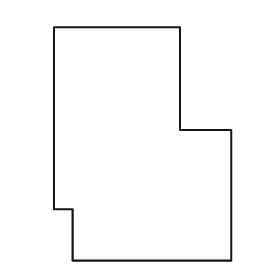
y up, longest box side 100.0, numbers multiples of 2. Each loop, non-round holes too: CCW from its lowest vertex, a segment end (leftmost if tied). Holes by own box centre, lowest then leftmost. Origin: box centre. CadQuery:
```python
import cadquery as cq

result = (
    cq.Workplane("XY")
    .moveTo(-30.0, -50.0)
    .lineTo(38.0, -50.0)
    .lineTo(38.0, 6.0)
    .lineTo(16.0, 6.0)
    .lineTo(16.0, 50.0)
    .lineTo(-38.0, 50.0)
    .lineTo(-38.0, -28.0)
    .lineTo(-30.0, -28.0)
    .close()
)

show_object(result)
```